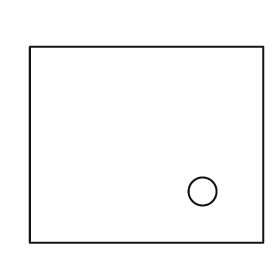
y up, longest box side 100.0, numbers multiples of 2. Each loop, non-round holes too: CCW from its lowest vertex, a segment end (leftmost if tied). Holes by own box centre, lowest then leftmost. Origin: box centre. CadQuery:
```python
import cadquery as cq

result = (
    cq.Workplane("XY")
    .moveTo(-50.0, -42.0)
    .lineTo(50.0, -42.0)
    .lineTo(50.0, 42.0)
    .lineTo(-50.0, 42.0)
    .close()
    .moveTo(24.0, -20.0)
    .circle(6.0)
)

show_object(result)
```